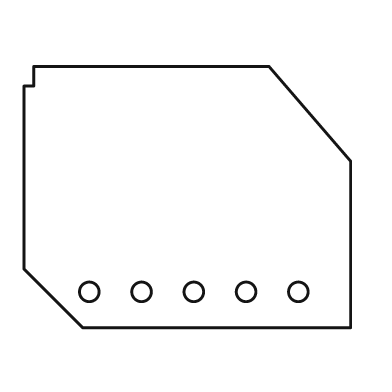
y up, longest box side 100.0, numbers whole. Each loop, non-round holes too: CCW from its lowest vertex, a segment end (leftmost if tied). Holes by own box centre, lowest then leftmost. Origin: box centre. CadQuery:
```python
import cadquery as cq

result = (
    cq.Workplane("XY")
    .moveTo(-32.0, -40.0)
    .lineTo(50.0, -40.0)
    .lineTo(50.0, 11.0)
    .lineTo(25.0, 40.0)
    .lineTo(-47.0, 40.0)
    .lineTo(-47.0, 34.0)
    .lineTo(-50.0, 34.0)
    .lineTo(-50.0, -22.0)
    .close()
    .moveTo(-30.0, -29.0)
    .circle(3.0)
    .moveTo(-14.0, -29.0)
    .circle(3.0)
    .moveTo(2.0, -29.0)
    .circle(3.0)
    .moveTo(18.0, -29.0)
    .circle(3.0)
    .moveTo(34.0, -29.0)
    .circle(3.0)
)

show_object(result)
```